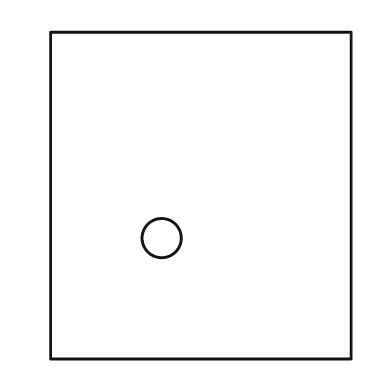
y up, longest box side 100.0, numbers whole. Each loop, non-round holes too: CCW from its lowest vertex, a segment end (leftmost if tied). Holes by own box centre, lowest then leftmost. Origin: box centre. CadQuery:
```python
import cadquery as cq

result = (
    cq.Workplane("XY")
    .moveTo(-46.0, -50.0)
    .lineTo(46.0, -50.0)
    .lineTo(46.0, 50.0)
    .lineTo(-46.0, 50.0)
    .close()
    .moveTo(-12.0, -13.0)
    .circle(6.0)
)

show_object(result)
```